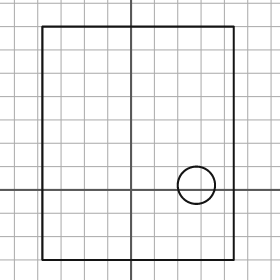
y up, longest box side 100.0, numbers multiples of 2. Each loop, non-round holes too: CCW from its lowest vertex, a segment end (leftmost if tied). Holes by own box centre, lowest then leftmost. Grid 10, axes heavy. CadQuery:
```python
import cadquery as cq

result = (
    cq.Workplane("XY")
    .moveTo(-38.0, -30.0)
    .lineTo(44.0, -30.0)
    .lineTo(44.0, 70.0)
    .lineTo(-38.0, 70.0)
    .close()
    .moveTo(28.0, 2.0)
    .circle(8.0)
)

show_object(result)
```